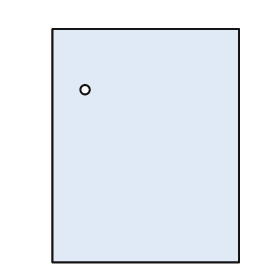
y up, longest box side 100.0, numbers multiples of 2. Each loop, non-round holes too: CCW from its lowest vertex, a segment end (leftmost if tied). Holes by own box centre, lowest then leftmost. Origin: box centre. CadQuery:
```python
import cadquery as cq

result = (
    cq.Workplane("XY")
    .moveTo(-40.0, -50.0)
    .lineTo(40.0, -50.0)
    .lineTo(40.0, 50.0)
    .lineTo(-40.0, 50.0)
    .close()
    .moveTo(-26.0, 24.0)
    .circle(2.0)
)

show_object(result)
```